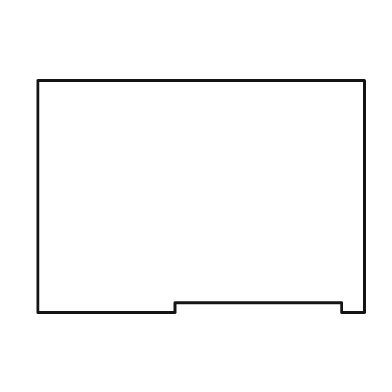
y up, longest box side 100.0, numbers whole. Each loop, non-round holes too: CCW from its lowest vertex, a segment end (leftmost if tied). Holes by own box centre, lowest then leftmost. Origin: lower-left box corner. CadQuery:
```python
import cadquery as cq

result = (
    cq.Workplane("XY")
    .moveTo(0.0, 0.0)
    .lineTo(42.0, 0.0)
    .lineTo(42.0, 3.0)
    .lineTo(93.0, 3.0)
    .lineTo(93.0, 0.0)
    .lineTo(100.0, 0.0)
    .lineTo(100.0, 71.0)
    .lineTo(0.0, 71.0)
    .close()
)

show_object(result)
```